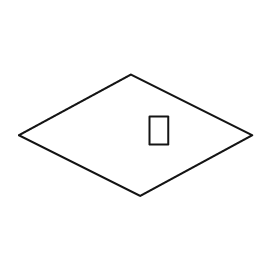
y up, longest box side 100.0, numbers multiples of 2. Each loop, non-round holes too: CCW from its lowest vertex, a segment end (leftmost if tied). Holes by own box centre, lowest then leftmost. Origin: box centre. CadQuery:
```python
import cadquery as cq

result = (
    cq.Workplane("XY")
    .moveTo(2.0, -26.0)
    .lineTo(50.0, 0.0)
    .lineTo(-2.0, 26.0)
    .lineTo(-50.0, 0.0)
    .close()
    .moveTo(6.0, -4.0)
    .lineTo(14.0, -4.0)
    .lineTo(14.0, 8.0)
    .lineTo(6.0, 8.0)
    .close()
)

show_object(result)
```